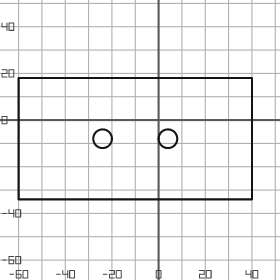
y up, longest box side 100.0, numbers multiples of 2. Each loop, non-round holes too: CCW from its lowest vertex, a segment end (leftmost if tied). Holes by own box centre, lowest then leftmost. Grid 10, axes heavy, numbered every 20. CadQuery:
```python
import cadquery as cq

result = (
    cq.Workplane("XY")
    .moveTo(-60.0, -34.0)
    .lineTo(40.0, -34.0)
    .lineTo(40.0, 18.0)
    .lineTo(-60.0, 18.0)
    .close()
    .moveTo(-24.0, -8.0)
    .circle(4.0)
    .moveTo(4.0, -8.0)
    .circle(4.0)
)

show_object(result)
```